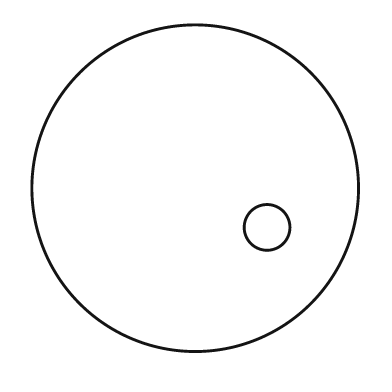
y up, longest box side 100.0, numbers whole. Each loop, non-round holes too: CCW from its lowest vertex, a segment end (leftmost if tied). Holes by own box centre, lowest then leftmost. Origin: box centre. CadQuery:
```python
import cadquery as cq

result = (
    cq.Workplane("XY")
    .moveTo(0.0, 0.0)
    .circle(50.0)
    .moveTo(22.0, -12.0)
    .circle(7.0)
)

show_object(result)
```